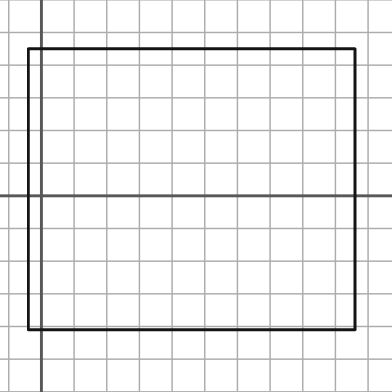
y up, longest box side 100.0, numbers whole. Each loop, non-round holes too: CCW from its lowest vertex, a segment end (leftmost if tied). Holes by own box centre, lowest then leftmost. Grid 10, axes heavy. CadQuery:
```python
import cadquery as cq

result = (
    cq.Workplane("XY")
    .moveTo(-4.0, -41.0)
    .lineTo(96.0, -41.0)
    .lineTo(96.0, 45.0)
    .lineTo(-4.0, 45.0)
    .close()
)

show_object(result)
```